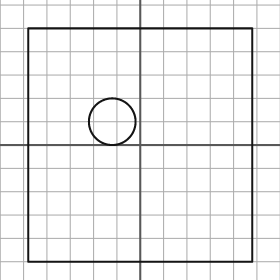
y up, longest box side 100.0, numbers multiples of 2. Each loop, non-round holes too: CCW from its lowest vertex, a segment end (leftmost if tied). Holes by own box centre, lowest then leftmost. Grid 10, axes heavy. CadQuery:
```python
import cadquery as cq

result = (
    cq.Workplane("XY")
    .moveTo(-48.0, -50.0)
    .lineTo(48.0, -50.0)
    .lineTo(48.0, 50.0)
    .lineTo(-48.0, 50.0)
    .close()
    .moveTo(-12.0, 10.0)
    .circle(10.0)
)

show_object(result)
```